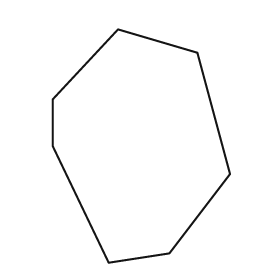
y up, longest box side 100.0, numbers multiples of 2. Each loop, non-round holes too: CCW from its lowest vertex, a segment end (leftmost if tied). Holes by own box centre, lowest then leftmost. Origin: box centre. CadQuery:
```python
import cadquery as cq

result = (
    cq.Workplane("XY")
    .moveTo(-14.0, -50.0)
    .lineTo(12.0, -46.0)
    .lineTo(38.0, -12.0)
    .lineTo(24.0, 40.0)
    .lineTo(-10.0, 50.0)
    .lineTo(-38.0, 20.0)
    .lineTo(-38.0, 0.0)
    .close()
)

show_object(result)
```